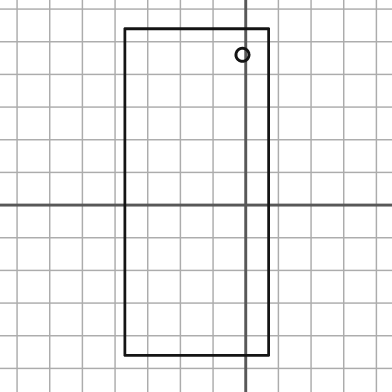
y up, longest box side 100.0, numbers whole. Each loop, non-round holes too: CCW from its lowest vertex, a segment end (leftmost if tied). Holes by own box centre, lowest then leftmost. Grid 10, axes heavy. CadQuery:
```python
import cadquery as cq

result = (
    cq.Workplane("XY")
    .moveTo(-37.0, -46.0)
    .lineTo(7.0, -46.0)
    .lineTo(7.0, 54.0)
    .lineTo(-37.0, 54.0)
    .close()
    .moveTo(-1.0, 46.0)
    .circle(2.0)
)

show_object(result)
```